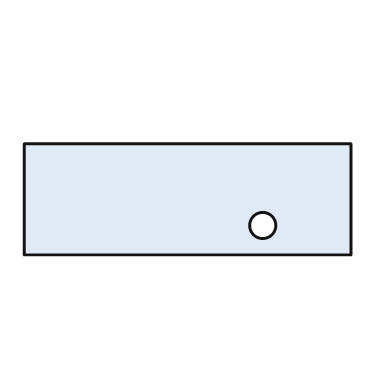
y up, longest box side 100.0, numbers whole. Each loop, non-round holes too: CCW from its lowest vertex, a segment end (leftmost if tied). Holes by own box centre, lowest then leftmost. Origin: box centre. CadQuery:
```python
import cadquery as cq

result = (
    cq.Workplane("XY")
    .moveTo(-50.0, -17.0)
    .lineTo(50.0, -17.0)
    .lineTo(50.0, 17.0)
    .lineTo(-50.0, 17.0)
    .close()
    .moveTo(23.0, -8.0)
    .circle(4.0)
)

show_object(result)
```